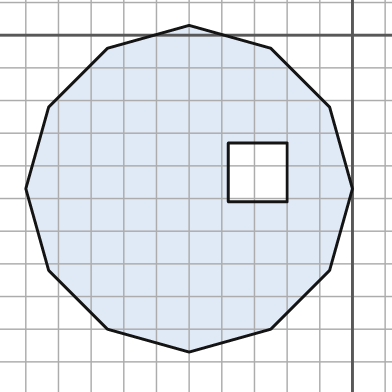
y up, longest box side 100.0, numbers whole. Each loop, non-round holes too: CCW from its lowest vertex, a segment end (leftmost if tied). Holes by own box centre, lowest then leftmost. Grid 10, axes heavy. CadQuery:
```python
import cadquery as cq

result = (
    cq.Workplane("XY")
    .moveTo(-50.0, -97.0)
    .lineTo(-25.0, -90.0)
    .lineTo(-7.0, -72.0)
    .lineTo(0.0, -47.0)
    .lineTo(-7.0, -22.0)
    .lineTo(-25.0, -4.0)
    .lineTo(-50.0, 3.0)
    .lineTo(-75.0, -4.0)
    .lineTo(-93.0, -22.0)
    .lineTo(-100.0, -47.0)
    .lineTo(-93.0, -72.0)
    .lineTo(-75.0, -90.0)
    .close()
    .moveTo(-38.0, -51.0)
    .lineTo(-20.0, -51.0)
    .lineTo(-20.0, -33.0)
    .lineTo(-38.0, -33.0)
    .close()
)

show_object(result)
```